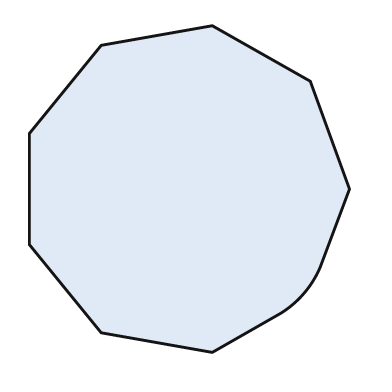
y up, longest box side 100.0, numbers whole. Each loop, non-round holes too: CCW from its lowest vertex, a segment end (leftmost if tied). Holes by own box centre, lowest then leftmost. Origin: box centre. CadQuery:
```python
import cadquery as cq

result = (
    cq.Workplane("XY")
    .moveTo(7.0, -50.0)
    .lineTo(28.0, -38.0)
    .threePointArc((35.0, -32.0), (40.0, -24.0))
    .lineTo(49.0, 0.0)
    .lineTo(37.0, 33.0)
    .lineTo(7.0, 50.0)
    .lineTo(-27.0, 44.0)
    .lineTo(-49.0, 17.0)
    .lineTo(-49.0, -17.0)
    .lineTo(-27.0, -44.0)
    .close()
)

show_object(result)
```